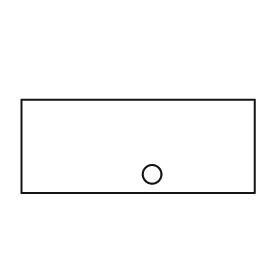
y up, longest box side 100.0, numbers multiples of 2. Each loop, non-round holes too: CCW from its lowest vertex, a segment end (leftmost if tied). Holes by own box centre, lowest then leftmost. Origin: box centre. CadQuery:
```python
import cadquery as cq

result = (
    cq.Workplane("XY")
    .moveTo(-50.0, -20.0)
    .lineTo(50.0, -20.0)
    .lineTo(50.0, 20.0)
    .lineTo(-50.0, 20.0)
    .close()
    .moveTo(6.0, -12.0)
    .circle(4.0)
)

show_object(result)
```